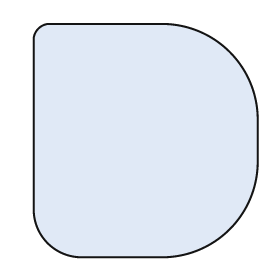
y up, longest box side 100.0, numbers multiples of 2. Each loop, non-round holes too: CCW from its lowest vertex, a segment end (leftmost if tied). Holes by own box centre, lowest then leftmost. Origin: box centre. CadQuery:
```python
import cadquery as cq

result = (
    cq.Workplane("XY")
    .moveTo(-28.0, -50.0)
    .lineTo(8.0, -50.0)
    .threePointArc((36.0, -38.0), (48.0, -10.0))
    .lineTo(48.0, 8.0)
    .threePointArc((36.0, 38.0), (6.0, 50.0))
    .lineTo(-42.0, 50.0)
    .threePointArc((-46.0, 48.0), (-48.0, 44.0))
    .lineTo(-48.0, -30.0)
    .threePointArc((-42.0, -44.0), (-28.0, -50.0))
    .close()
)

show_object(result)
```